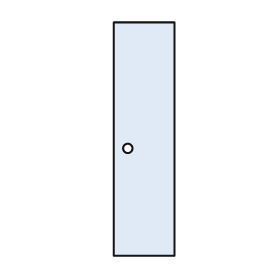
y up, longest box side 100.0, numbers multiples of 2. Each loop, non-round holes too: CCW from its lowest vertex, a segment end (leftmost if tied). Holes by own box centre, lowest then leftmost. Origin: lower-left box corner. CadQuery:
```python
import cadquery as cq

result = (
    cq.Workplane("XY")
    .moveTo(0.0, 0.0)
    .lineTo(26.0, 0.0)
    .lineTo(26.0, 100.0)
    .lineTo(0.0, 100.0)
    .close()
    .moveTo(6.0, 46.0)
    .circle(2.0)
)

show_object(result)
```